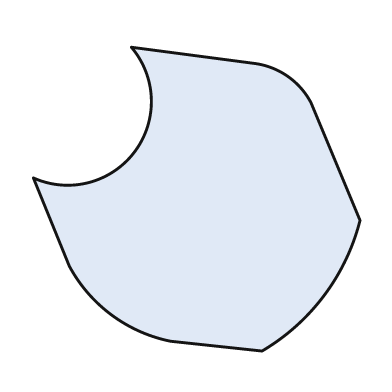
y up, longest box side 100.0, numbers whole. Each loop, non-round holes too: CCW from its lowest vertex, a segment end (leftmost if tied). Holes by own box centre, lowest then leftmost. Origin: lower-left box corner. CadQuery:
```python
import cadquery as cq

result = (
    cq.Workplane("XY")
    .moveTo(70.0, 0.0)
    .threePointArc((89.0, 17.0), (100.0, 40.0))
    .lineTo(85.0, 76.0)
    .threePointArc((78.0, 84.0), (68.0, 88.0))
    .lineTo(30.0, 93.0)
    .threePointArc((31.0, 61.0), (0.0, 53.0))
    .lineTo(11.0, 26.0)
    .threePointArc((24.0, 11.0), (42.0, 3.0))
    .close()
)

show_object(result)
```